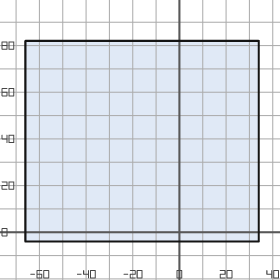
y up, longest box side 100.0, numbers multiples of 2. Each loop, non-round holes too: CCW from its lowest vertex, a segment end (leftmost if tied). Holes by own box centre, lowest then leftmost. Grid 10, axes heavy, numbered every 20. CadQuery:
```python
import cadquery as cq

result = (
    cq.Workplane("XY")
    .moveTo(-66.0, -4.0)
    .lineTo(34.0, -4.0)
    .lineTo(34.0, 82.0)
    .lineTo(-66.0, 82.0)
    .close()
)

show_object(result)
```